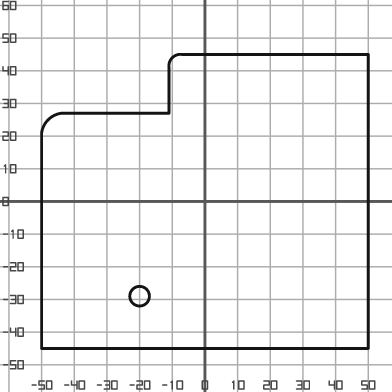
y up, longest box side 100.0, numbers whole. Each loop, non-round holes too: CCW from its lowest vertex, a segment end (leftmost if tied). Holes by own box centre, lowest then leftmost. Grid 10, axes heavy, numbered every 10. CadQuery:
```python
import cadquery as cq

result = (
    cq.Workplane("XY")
    .moveTo(-50.0, -45.0)
    .lineTo(50.0, -45.0)
    .lineTo(50.0, 45.0)
    .lineTo(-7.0, 45.0)
    .threePointArc((-10.0, 44.0), (-11.0, 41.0))
    .lineTo(-11.0, 27.0)
    .lineTo(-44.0, 27.0)
    .threePointArc((-48.0, 25.0), (-50.0, 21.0))
    .close()
    .moveTo(-20.0, -29.0)
    .circle(3.0)
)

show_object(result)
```